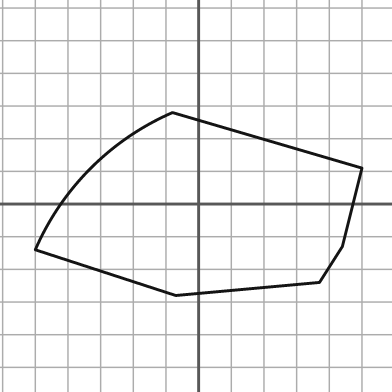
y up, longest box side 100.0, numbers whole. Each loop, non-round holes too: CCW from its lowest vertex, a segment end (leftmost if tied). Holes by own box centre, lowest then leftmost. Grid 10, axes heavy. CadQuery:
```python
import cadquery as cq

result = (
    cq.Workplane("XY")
    .moveTo(-7.0, -28.0)
    .lineTo(37.0, -24.0)
    .lineTo(44.0, -13.0)
    .lineTo(50.0, 11.0)
    .lineTo(-8.0, 28.0)
    .threePointArc((-33.0, 11.0), (-50.0, -14.0))
    .close()
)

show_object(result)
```